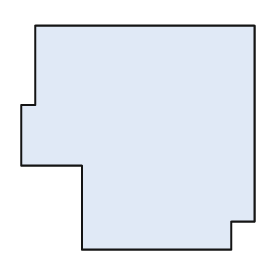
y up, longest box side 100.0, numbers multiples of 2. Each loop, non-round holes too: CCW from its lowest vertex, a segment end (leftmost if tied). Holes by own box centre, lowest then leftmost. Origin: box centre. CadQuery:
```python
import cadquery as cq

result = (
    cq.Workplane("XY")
    .moveTo(-24.0, -48.0)
    .lineTo(40.0, -48.0)
    .lineTo(40.0, -36.0)
    .lineTo(50.0, -36.0)
    .lineTo(50.0, 48.0)
    .lineTo(-44.0, 48.0)
    .lineTo(-44.0, 14.0)
    .lineTo(-50.0, 14.0)
    .lineTo(-50.0, -12.0)
    .lineTo(-24.0, -12.0)
    .close()
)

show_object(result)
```